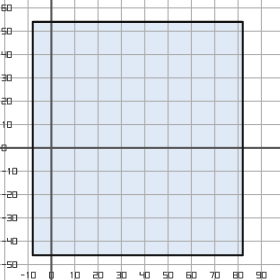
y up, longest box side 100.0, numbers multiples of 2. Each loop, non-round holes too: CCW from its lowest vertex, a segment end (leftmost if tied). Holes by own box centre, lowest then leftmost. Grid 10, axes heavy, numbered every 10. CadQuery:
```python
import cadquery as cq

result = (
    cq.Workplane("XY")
    .moveTo(-8.0, -46.0)
    .lineTo(82.0, -46.0)
    .lineTo(82.0, 54.0)
    .lineTo(-8.0, 54.0)
    .close()
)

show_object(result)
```